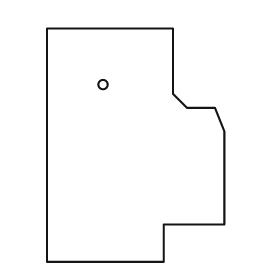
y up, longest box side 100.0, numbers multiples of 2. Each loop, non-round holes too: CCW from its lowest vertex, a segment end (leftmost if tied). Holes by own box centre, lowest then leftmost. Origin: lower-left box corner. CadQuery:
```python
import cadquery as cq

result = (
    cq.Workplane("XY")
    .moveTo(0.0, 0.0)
    .lineTo(50.0, 0.0)
    .lineTo(50.0, 16.0)
    .lineTo(76.0, 16.0)
    .lineTo(76.0, 56.0)
    .lineTo(72.0, 66.0)
    .lineTo(60.0, 66.0)
    .lineTo(54.0, 72.0)
    .lineTo(54.0, 100.0)
    .lineTo(0.0, 100.0)
    .close()
    .moveTo(24.0, 76.0)
    .circle(2.0)
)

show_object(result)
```